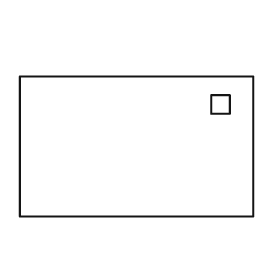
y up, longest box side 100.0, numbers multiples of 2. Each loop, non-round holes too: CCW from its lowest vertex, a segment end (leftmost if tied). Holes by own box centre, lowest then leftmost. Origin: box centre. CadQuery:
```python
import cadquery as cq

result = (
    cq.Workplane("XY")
    .moveTo(-50.0, -30.0)
    .lineTo(50.0, -30.0)
    .lineTo(50.0, 30.0)
    .lineTo(-50.0, 30.0)
    .close()
    .moveTo(32.0, 14.0)
    .lineTo(40.0, 14.0)
    .lineTo(40.0, 22.0)
    .lineTo(32.0, 22.0)
    .close()
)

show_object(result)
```